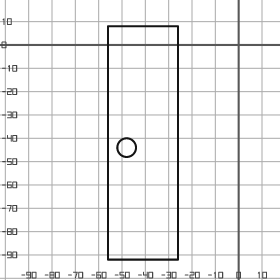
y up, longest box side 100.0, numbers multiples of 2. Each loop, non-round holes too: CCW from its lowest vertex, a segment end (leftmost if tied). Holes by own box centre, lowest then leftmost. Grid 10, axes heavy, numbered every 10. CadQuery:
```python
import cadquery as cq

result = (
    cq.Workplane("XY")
    .moveTo(-56.0, -92.0)
    .lineTo(-26.0, -92.0)
    .lineTo(-26.0, 8.0)
    .lineTo(-56.0, 8.0)
    .close()
    .moveTo(-48.0, -44.0)
    .circle(4.0)
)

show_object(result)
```